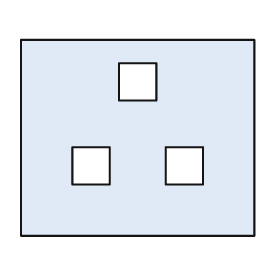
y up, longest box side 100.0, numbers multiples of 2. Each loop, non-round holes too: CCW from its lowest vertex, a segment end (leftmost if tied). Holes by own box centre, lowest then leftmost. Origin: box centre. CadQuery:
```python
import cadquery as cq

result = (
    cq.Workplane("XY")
    .moveTo(-50.0, -42.0)
    .lineTo(50.0, -42.0)
    .lineTo(50.0, 42.0)
    .lineTo(-50.0, 42.0)
    .close()
    .moveTo(-28.0, -20.0)
    .lineTo(-12.0, -20.0)
    .lineTo(-12.0, -4.0)
    .lineTo(-28.0, -4.0)
    .close()
    .moveTo(12.0, -20.0)
    .lineTo(28.0, -20.0)
    .lineTo(28.0, -4.0)
    .lineTo(12.0, -4.0)
    .close()
    .moveTo(-8.0, 16.0)
    .lineTo(8.0, 16.0)
    .lineTo(8.0, 32.0)
    .lineTo(-8.0, 32.0)
    .close()
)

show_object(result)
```